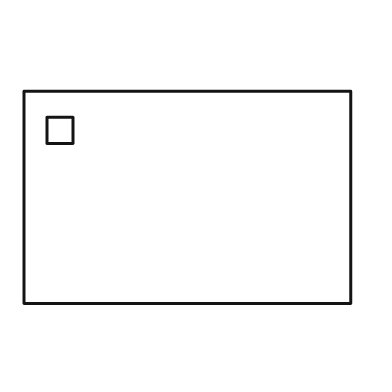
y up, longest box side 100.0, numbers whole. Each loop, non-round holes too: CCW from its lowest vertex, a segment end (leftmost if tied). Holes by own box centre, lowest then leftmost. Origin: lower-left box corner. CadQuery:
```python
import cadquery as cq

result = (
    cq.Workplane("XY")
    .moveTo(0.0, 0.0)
    .lineTo(100.0, 0.0)
    .lineTo(100.0, 65.0)
    .lineTo(0.0, 65.0)
    .close()
    .moveTo(7.0, 49.0)
    .lineTo(15.0, 49.0)
    .lineTo(15.0, 57.0)
    .lineTo(7.0, 57.0)
    .close()
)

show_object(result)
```